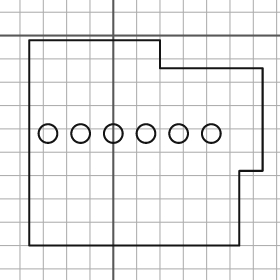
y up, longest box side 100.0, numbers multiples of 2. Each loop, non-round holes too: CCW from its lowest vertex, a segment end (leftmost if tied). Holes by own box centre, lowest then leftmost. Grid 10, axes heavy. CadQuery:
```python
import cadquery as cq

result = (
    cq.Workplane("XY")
    .moveTo(-36.0, -90.0)
    .lineTo(54.0, -90.0)
    .lineTo(54.0, -58.0)
    .lineTo(64.0, -58.0)
    .lineTo(64.0, -14.0)
    .lineTo(20.0, -14.0)
    .lineTo(20.0, -2.0)
    .lineTo(-36.0, -2.0)
    .close()
    .moveTo(-28.0, -42.0)
    .circle(4.0)
    .moveTo(-14.0, -42.0)
    .circle(4.0)
    .moveTo(0.0, -42.0)
    .circle(4.0)
    .moveTo(14.0, -42.0)
    .circle(4.0)
    .moveTo(28.0, -42.0)
    .circle(4.0)
    .moveTo(42.0, -42.0)
    .circle(4.0)
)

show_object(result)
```